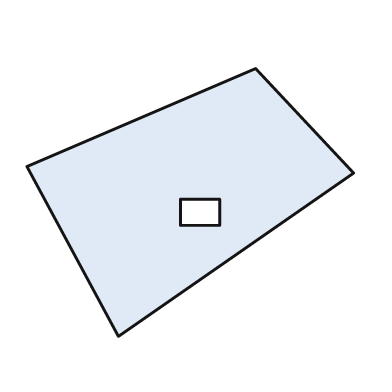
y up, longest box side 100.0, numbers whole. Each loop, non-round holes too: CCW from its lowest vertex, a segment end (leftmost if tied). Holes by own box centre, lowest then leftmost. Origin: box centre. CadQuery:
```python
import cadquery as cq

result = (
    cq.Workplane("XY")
    .moveTo(-22.0, -41.0)
    .lineTo(50.0, 9.0)
    .lineTo(20.0, 41.0)
    .lineTo(-50.0, 11.0)
    .close()
    .moveTo(-3.0, -7.0)
    .lineTo(9.0, -7.0)
    .lineTo(9.0, 1.0)
    .lineTo(-3.0, 1.0)
    .close()
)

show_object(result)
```